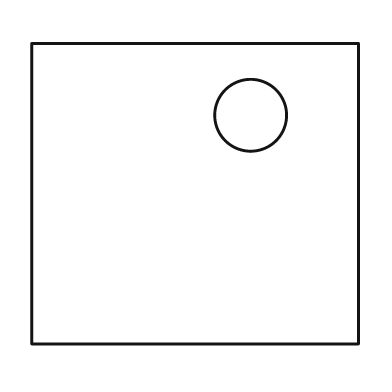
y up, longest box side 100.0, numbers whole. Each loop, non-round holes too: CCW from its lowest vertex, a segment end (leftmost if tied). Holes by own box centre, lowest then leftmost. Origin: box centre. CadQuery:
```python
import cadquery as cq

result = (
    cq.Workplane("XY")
    .moveTo(-50.0, -46.0)
    .lineTo(50.0, -46.0)
    .lineTo(50.0, 46.0)
    .lineTo(-50.0, 46.0)
    .close()
    .moveTo(17.0, 24.0)
    .circle(11.0)
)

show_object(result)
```